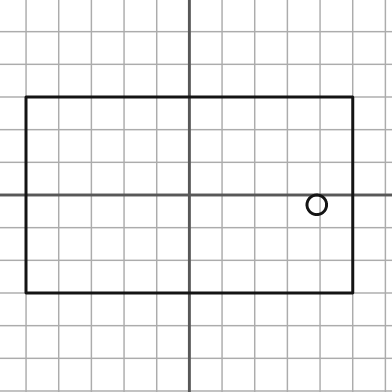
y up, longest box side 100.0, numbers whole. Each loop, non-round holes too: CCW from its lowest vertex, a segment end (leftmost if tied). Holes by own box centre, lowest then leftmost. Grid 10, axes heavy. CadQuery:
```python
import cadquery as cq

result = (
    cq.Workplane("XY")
    .moveTo(-50.0, -30.0)
    .lineTo(50.0, -30.0)
    .lineTo(50.0, 30.0)
    .lineTo(-50.0, 30.0)
    .close()
    .moveTo(39.0, -3.0)
    .circle(3.0)
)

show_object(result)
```